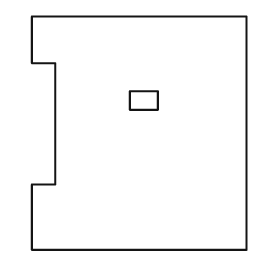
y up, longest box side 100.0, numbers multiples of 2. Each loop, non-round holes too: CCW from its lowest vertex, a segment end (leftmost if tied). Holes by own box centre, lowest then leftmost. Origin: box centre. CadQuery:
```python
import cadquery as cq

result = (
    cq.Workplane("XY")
    .moveTo(-46.0, -50.0)
    .lineTo(46.0, -50.0)
    .lineTo(46.0, 50.0)
    .lineTo(-46.0, 50.0)
    .lineTo(-46.0, 30.0)
    .lineTo(-36.0, 30.0)
    .lineTo(-36.0, -22.0)
    .lineTo(-46.0, -22.0)
    .close()
    .moveTo(-4.0, 10.0)
    .lineTo(8.0, 10.0)
    .lineTo(8.0, 18.0)
    .lineTo(-4.0, 18.0)
    .close()
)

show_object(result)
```